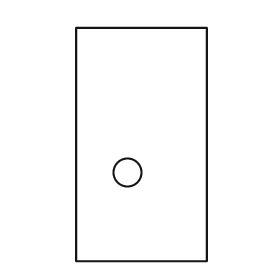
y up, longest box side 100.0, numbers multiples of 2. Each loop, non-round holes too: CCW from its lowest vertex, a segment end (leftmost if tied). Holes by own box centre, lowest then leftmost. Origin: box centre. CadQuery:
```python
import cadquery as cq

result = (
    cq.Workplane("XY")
    .moveTo(-28.0, -50.0)
    .lineTo(28.0, -50.0)
    .lineTo(28.0, 50.0)
    .lineTo(-28.0, 50.0)
    .close()
    .moveTo(-6.0, -12.0)
    .circle(6.0)
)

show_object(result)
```